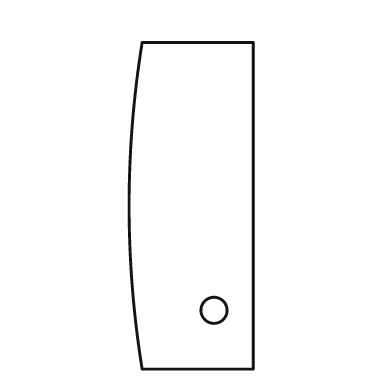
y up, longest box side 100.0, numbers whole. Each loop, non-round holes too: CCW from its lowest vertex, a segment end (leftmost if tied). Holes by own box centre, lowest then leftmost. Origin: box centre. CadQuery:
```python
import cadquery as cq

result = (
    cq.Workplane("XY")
    .moveTo(-15.0, -50.0)
    .lineTo(19.0, -50.0)
    .lineTo(19.0, 50.0)
    .lineTo(-15.0, 50.0)
    .threePointArc((-19.0, 0.0), (-15.0, -50.0))
    .close()
    .moveTo(7.0, -32.0)
    .circle(4.0)
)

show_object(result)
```